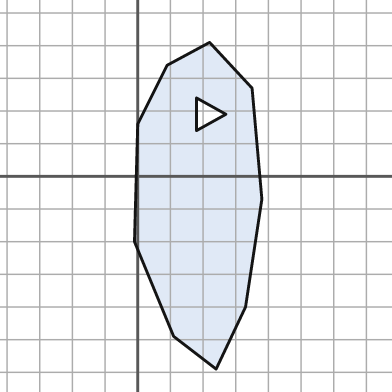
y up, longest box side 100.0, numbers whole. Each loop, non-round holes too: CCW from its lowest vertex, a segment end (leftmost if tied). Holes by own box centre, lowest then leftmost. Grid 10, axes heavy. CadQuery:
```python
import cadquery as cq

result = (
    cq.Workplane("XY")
    .moveTo(24.0, -59.0)
    .lineTo(33.0, -40.0)
    .lineTo(38.0, -7.0)
    .lineTo(35.0, 27.0)
    .lineTo(22.0, 41.0)
    .lineTo(9.0, 34.0)
    .lineTo(0.0, 16.0)
    .lineTo(-1.0, -20.0)
    .lineTo(11.0, -49.0)
    .close()
    .moveTo(18.0, 14.0)
    .lineTo(27.0, 19.0)
    .lineTo(18.0, 24.0)
    .close()
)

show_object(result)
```